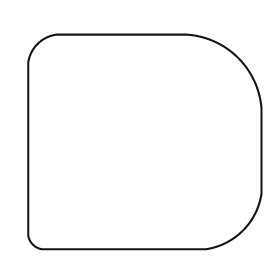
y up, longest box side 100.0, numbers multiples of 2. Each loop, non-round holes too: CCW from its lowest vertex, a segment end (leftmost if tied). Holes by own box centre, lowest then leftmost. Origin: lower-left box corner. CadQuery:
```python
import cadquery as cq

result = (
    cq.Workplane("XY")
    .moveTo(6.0, 0.0)
    .lineTo(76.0, 0.0)
    .threePointArc((92.0, 8.0), (100.0, 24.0))
    .lineTo(100.0, 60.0)
    .threePointArc((90.0, 82.0), (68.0, 92.0))
    .lineTo(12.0, 92.0)
    .threePointArc((4.0, 88.0), (0.0, 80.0))
    .lineTo(0.0, 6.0)
    .threePointArc((2.0, 2.0), (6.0, 0.0))
    .close()
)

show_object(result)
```